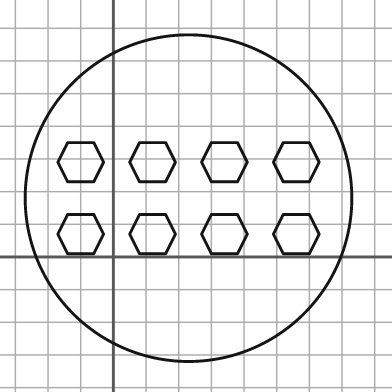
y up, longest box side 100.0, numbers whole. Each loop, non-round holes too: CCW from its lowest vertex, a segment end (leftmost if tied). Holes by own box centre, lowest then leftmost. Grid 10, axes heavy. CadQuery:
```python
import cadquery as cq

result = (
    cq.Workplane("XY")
    .moveTo(23.0, 18.0)
    .circle(50.0)
    .moveTo(-14.0, 1.0)
    .lineTo(-6.0, 1.0)
    .lineTo(-3.0, 7.0)
    .lineTo(-6.0, 13.0)
    .lineTo(-14.0, 13.0)
    .lineTo(-17.0, 7.0)
    .close()
    .moveTo(8.0, 1.0)
    .lineTo(16.0, 1.0)
    .lineTo(19.0, 7.0)
    .lineTo(16.0, 13.0)
    .lineTo(8.0, 13.0)
    .lineTo(5.0, 7.0)
    .close()
    .moveTo(30.0, 1.0)
    .lineTo(38.0, 1.0)
    .lineTo(41.0, 7.0)
    .lineTo(38.0, 13.0)
    .lineTo(30.0, 13.0)
    .lineTo(27.0, 7.0)
    .close()
    .moveTo(52.0, 1.0)
    .lineTo(60.0, 1.0)
    .lineTo(63.0, 7.0)
    .lineTo(60.0, 13.0)
    .lineTo(52.0, 13.0)
    .lineTo(49.0, 7.0)
    .close()
    .moveTo(-14.0, 23.0)
    .lineTo(-6.0, 23.0)
    .lineTo(-3.0, 29.0)
    .lineTo(-6.0, 35.0)
    .lineTo(-14.0, 35.0)
    .lineTo(-17.0, 29.0)
    .close()
    .moveTo(8.0, 23.0)
    .lineTo(16.0, 23.0)
    .lineTo(19.0, 29.0)
    .lineTo(16.0, 35.0)
    .lineTo(8.0, 35.0)
    .lineTo(5.0, 29.0)
    .close()
    .moveTo(30.0, 23.0)
    .lineTo(38.0, 23.0)
    .lineTo(41.0, 29.0)
    .lineTo(38.0, 35.0)
    .lineTo(30.0, 35.0)
    .lineTo(27.0, 29.0)
    .close()
    .moveTo(52.0, 23.0)
    .lineTo(60.0, 23.0)
    .lineTo(63.0, 29.0)
    .lineTo(60.0, 35.0)
    .lineTo(52.0, 35.0)
    .lineTo(49.0, 29.0)
    .close()
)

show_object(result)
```